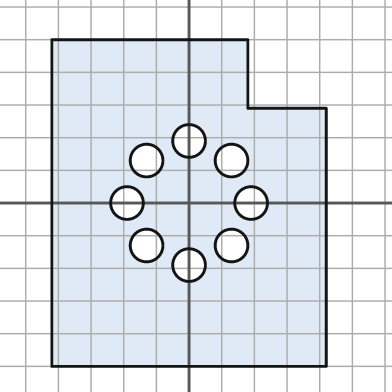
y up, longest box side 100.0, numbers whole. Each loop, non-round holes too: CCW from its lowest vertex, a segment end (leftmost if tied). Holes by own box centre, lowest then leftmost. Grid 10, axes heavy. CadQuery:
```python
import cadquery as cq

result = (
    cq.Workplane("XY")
    .moveTo(-42.0, -50.0)
    .lineTo(42.0, -50.0)
    .lineTo(42.0, 29.0)
    .lineTo(18.0, 29.0)
    .lineTo(18.0, 50.0)
    .lineTo(-42.0, 50.0)
    .close()
    .moveTo(0.0, -19.0)
    .circle(5.0)
    .moveTo(-13.0, -13.0)
    .circle(5.0)
    .moveTo(13.0, -13.0)
    .circle(5.0)
    .moveTo(-19.0, 0.0)
    .circle(5.0)
    .moveTo(19.0, 0.0)
    .circle(5.0)
    .moveTo(-13.0, 13.0)
    .circle(5.0)
    .moveTo(13.0, 13.0)
    .circle(5.0)
    .moveTo(0.0, 19.0)
    .circle(5.0)
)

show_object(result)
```